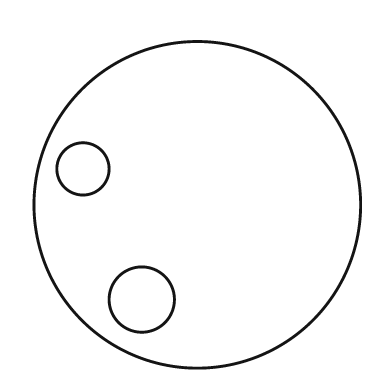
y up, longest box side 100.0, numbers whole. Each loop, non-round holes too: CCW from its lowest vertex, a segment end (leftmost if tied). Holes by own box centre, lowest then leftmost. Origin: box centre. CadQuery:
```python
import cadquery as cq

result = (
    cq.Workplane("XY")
    .moveTo(0.0, 0.0)
    .circle(50.0)
    .moveTo(-17.0, -29.0)
    .circle(10.0)
    .moveTo(-35.0, 11.0)
    .circle(8.0)
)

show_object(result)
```